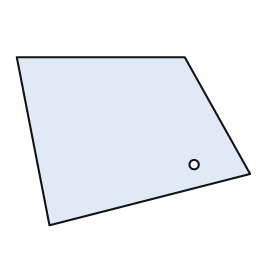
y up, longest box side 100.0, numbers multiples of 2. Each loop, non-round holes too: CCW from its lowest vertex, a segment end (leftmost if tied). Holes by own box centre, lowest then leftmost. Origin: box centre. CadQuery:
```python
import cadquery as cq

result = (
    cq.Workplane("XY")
    .moveTo(-36.0, -36.0)
    .lineTo(50.0, -14.0)
    .lineTo(22.0, 36.0)
    .lineTo(-50.0, 36.0)
    .close()
    .moveTo(26.0, -10.0)
    .circle(2.0)
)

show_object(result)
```